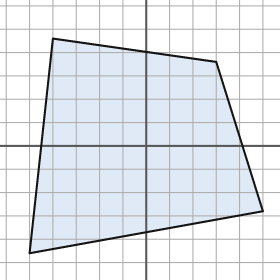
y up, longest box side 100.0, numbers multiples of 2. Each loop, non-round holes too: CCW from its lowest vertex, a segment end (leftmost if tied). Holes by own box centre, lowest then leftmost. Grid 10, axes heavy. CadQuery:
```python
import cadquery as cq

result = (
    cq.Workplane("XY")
    .moveTo(-50.0, -46.0)
    .lineTo(50.0, -28.0)
    .lineTo(30.0, 36.0)
    .lineTo(-40.0, 46.0)
    .close()
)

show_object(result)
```